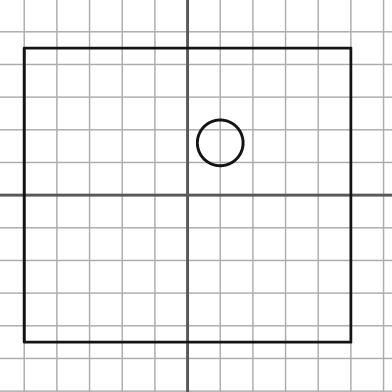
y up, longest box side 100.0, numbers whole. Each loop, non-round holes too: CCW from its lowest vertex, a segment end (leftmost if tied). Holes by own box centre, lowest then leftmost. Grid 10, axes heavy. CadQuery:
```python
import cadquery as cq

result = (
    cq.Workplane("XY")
    .moveTo(-50.0, -45.0)
    .lineTo(50.0, -45.0)
    .lineTo(50.0, 45.0)
    .lineTo(-50.0, 45.0)
    .close()
    .moveTo(10.0, 16.0)
    .circle(7.0)
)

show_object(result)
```